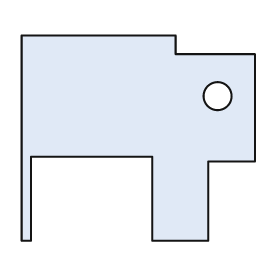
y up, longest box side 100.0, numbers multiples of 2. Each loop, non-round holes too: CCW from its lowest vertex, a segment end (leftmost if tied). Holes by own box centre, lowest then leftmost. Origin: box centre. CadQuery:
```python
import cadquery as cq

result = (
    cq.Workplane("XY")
    .moveTo(-50.0, -44.0)
    .lineTo(-46.0, -44.0)
    .lineTo(-46.0, -8.0)
    .lineTo(6.0, -8.0)
    .lineTo(6.0, -44.0)
    .lineTo(30.0, -44.0)
    .lineTo(30.0, -10.0)
    .lineTo(50.0, -10.0)
    .lineTo(50.0, 36.0)
    .lineTo(16.0, 36.0)
    .lineTo(16.0, 44.0)
    .lineTo(-50.0, 44.0)
    .close()
    .moveTo(34.0, 18.0)
    .circle(6.0)
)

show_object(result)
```